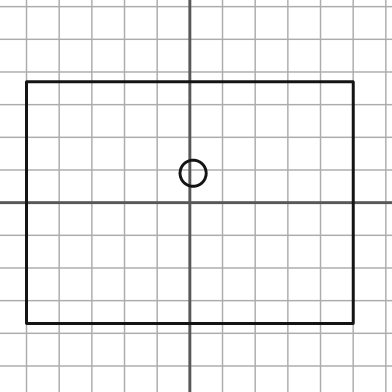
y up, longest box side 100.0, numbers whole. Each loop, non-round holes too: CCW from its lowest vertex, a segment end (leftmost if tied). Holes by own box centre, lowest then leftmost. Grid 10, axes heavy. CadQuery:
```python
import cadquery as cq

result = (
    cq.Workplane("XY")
    .moveTo(-50.0, -37.0)
    .lineTo(50.0, -37.0)
    .lineTo(50.0, 37.0)
    .lineTo(-50.0, 37.0)
    .close()
    .moveTo(1.0, 9.0)
    .circle(4.0)
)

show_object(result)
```